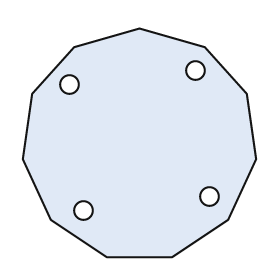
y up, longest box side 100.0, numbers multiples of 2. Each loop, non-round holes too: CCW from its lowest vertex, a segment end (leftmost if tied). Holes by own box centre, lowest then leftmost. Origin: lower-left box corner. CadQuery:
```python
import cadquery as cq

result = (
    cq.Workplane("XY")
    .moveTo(36.0, 0.0)
    .lineTo(64.0, 0.0)
    .lineTo(88.0, 16.0)
    .lineTo(100.0, 42.0)
    .lineTo(96.0, 70.0)
    .lineTo(78.0, 90.0)
    .lineTo(50.0, 98.0)
    .lineTo(22.0, 90.0)
    .lineTo(4.0, 70.0)
    .lineTo(0.0, 42.0)
    .lineTo(12.0, 16.0)
    .close()
    .moveTo(26.0, 20.0)
    .circle(4.0)
    .moveTo(80.0, 26.0)
    .circle(4.0)
    .moveTo(20.0, 74.0)
    .circle(4.0)
    .moveTo(74.0, 80.0)
    .circle(4.0)
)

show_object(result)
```